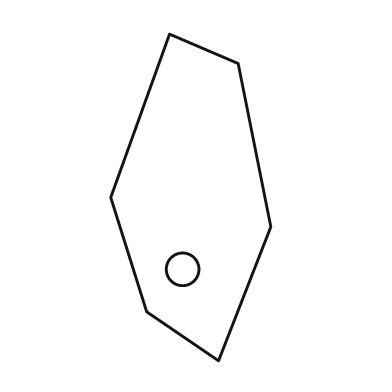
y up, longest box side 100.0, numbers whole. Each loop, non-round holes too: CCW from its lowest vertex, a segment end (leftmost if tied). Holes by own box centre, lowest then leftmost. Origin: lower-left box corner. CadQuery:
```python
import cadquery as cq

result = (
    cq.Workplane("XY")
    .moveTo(33.0, 0.0)
    .lineTo(49.0, 41.0)
    .lineTo(39.0, 91.0)
    .lineTo(18.0, 100.0)
    .lineTo(0.0, 50.0)
    .lineTo(11.0, 15.0)
    .close()
    .moveTo(22.0, 28.0)
    .circle(5.0)
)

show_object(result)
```